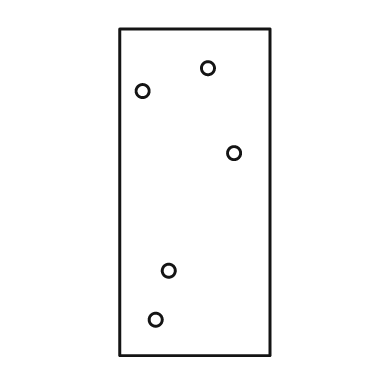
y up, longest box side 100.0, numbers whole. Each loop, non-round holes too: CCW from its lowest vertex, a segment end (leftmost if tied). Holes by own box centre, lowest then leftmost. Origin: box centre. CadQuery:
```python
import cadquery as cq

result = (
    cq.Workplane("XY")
    .moveTo(-23.0, -50.0)
    .lineTo(23.0, -50.0)
    .lineTo(23.0, 50.0)
    .lineTo(-23.0, 50.0)
    .close()
    .moveTo(-12.0, -39.0)
    .circle(2.0)
    .moveTo(-8.0, -24.0)
    .circle(2.0)
    .moveTo(12.0, 12.0)
    .circle(2.0)
    .moveTo(-16.0, 31.0)
    .circle(2.0)
    .moveTo(4.0, 38.0)
    .circle(2.0)
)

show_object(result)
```